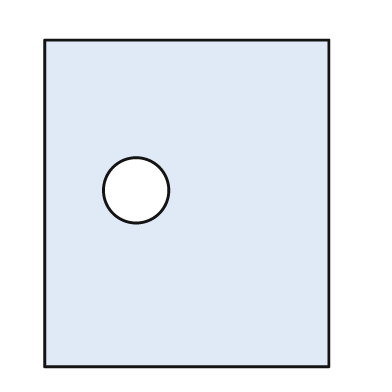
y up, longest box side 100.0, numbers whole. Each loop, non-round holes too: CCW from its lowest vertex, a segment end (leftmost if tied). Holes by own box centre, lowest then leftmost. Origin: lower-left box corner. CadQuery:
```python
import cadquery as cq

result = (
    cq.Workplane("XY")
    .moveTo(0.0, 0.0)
    .lineTo(87.0, 0.0)
    .lineTo(87.0, 100.0)
    .lineTo(0.0, 100.0)
    .close()
    .moveTo(28.0, 54.0)
    .circle(10.0)
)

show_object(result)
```